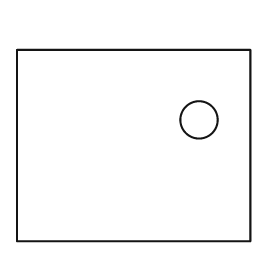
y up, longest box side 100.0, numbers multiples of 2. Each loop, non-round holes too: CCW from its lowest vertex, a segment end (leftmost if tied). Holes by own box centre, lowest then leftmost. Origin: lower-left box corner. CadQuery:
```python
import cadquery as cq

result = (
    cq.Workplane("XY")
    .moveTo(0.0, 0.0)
    .lineTo(100.0, 0.0)
    .lineTo(100.0, 82.0)
    .lineTo(0.0, 82.0)
    .close()
    .moveTo(78.0, 52.0)
    .circle(8.0)
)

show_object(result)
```